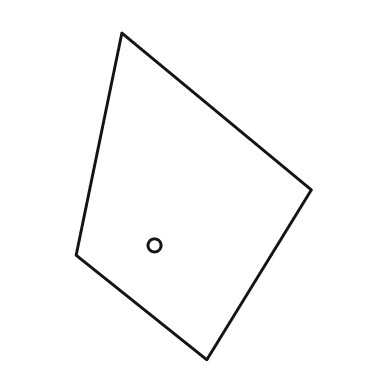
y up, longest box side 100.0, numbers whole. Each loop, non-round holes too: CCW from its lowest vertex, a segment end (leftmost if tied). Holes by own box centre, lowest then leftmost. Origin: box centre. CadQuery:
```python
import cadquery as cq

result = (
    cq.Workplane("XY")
    .moveTo(4.0, -50.0)
    .lineTo(36.0, 2.0)
    .lineTo(-22.0, 50.0)
    .lineTo(-36.0, -18.0)
    .close()
    .moveTo(-12.0, -15.0)
    .circle(2.0)
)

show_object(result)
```